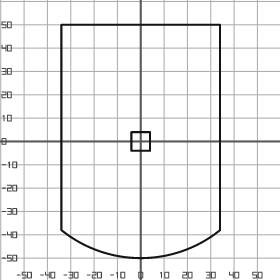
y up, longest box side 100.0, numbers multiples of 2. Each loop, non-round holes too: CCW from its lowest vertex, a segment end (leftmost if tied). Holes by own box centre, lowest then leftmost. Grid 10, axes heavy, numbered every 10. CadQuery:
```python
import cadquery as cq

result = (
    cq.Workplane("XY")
    .moveTo(-34.0, -38.0)
    .threePointArc((0.0, -50.0), (34.0, -38.0))
    .lineTo(34.0, 50.0)
    .lineTo(-34.0, 50.0)
    .close()
    .moveTo(-4.0, -4.0)
    .lineTo(4.0, -4.0)
    .lineTo(4.0, 4.0)
    .lineTo(-4.0, 4.0)
    .close()
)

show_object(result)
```